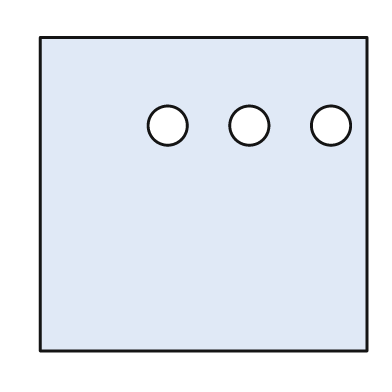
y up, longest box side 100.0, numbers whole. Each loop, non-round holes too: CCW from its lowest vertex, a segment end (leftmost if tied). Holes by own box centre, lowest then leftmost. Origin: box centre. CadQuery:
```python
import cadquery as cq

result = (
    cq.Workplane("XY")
    .moveTo(-50.0, -48.0)
    .lineTo(50.0, -48.0)
    .lineTo(50.0, 48.0)
    .lineTo(-50.0, 48.0)
    .close()
    .moveTo(-11.0, 21.0)
    .circle(6.0)
    .moveTo(14.0, 21.0)
    .circle(6.0)
    .moveTo(39.0, 21.0)
    .circle(6.0)
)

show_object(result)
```